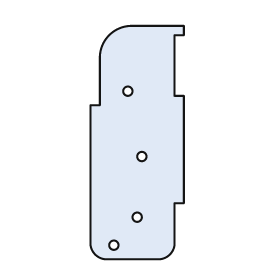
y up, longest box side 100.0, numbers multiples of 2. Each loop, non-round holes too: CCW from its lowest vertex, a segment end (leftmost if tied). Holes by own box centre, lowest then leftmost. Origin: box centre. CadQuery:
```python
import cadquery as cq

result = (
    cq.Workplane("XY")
    .moveTo(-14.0, -50.0)
    .lineTo(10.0, -50.0)
    .threePointArc((14.0, -48.0), (16.0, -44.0))
    .lineTo(16.0, -26.0)
    .lineTo(20.0, -26.0)
    .lineTo(20.0, 20.0)
    .lineTo(16.0, 20.0)
    .lineTo(16.0, 46.0)
    .lineTo(20.0, 46.0)
    .lineTo(20.0, 50.0)
    .lineTo(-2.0, 50.0)
    .threePointArc((-12.0, 46.0), (-16.0, 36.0))
    .lineTo(-16.0, 16.0)
    .lineTo(-20.0, 16.0)
    .lineTo(-20.0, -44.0)
    .threePointArc((-18.0, -48.0), (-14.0, -50.0))
    .close()
    .moveTo(-10.0, -44.0)
    .circle(2.0)
    .moveTo(0.0, -32.0)
    .circle(2.0)
    .moveTo(2.0, -6.0)
    .circle(2.0)
    .moveTo(-4.0, 22.0)
    .circle(2.0)
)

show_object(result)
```